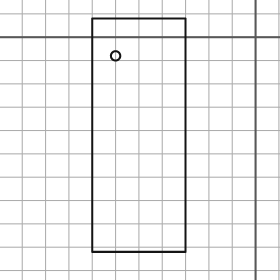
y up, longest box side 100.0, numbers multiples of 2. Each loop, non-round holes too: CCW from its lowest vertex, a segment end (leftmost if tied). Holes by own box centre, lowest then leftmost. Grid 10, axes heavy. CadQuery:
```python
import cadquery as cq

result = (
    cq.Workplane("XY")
    .moveTo(-70.0, -92.0)
    .lineTo(-30.0, -92.0)
    .lineTo(-30.0, 8.0)
    .lineTo(-70.0, 8.0)
    .close()
    .moveTo(-60.0, -8.0)
    .circle(2.0)
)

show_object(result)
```